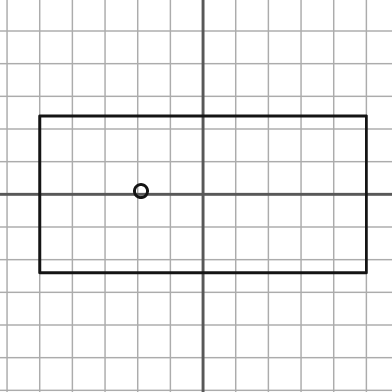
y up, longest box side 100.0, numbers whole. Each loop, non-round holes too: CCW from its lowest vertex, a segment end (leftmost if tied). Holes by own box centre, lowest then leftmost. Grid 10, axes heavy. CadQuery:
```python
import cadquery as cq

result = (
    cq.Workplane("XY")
    .moveTo(-50.0, -24.0)
    .lineTo(50.0, -24.0)
    .lineTo(50.0, 24.0)
    .lineTo(-50.0, 24.0)
    .close()
    .moveTo(-19.0, 1.0)
    .circle(2.0)
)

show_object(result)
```